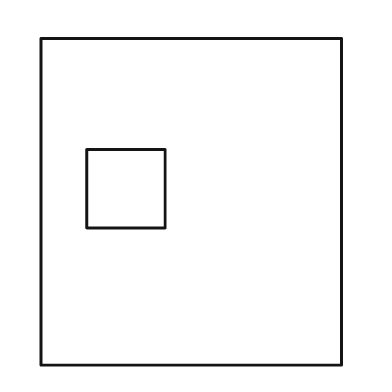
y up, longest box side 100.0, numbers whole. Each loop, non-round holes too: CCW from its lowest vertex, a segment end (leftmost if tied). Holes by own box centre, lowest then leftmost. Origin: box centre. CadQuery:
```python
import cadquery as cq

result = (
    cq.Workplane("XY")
    .moveTo(-46.0, -50.0)
    .lineTo(46.0, -50.0)
    .lineTo(46.0, 50.0)
    .lineTo(-46.0, 50.0)
    .close()
    .moveTo(-32.0, -8.0)
    .lineTo(-8.0, -8.0)
    .lineTo(-8.0, 16.0)
    .lineTo(-32.0, 16.0)
    .close()
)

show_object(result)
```